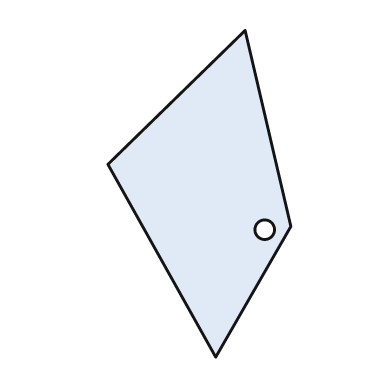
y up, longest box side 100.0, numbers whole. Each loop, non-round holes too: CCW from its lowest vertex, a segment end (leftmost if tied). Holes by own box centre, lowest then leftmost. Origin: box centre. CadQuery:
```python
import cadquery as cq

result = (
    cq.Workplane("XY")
    .moveTo(5.0, -50.0)
    .lineTo(28.0, -10.0)
    .lineTo(14.0, 50.0)
    .lineTo(-28.0, 9.0)
    .close()
    .moveTo(20.0, -11.0)
    .circle(3.0)
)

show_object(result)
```